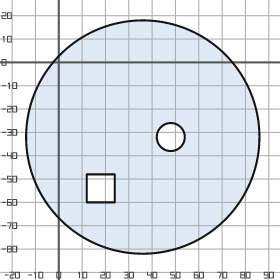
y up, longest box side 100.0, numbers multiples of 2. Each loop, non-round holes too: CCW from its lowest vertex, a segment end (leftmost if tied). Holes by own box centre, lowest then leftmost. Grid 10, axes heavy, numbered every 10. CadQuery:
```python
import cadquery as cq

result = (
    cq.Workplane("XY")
    .moveTo(36.0, -32.0)
    .circle(50.0)
    .moveTo(12.0, -60.0)
    .lineTo(24.0, -60.0)
    .lineTo(24.0, -48.0)
    .lineTo(12.0, -48.0)
    .close()
    .moveTo(48.0, -32.0)
    .circle(6.0)
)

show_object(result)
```